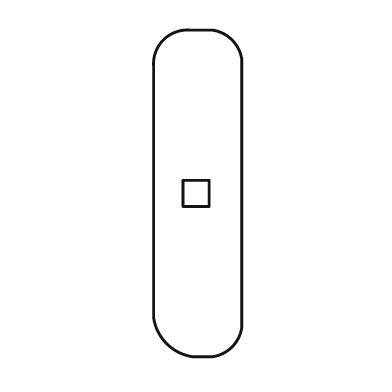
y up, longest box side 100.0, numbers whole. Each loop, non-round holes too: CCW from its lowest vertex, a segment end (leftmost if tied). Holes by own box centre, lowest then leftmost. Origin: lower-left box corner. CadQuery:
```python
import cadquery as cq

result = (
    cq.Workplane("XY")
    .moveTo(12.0, 0.0)
    .lineTo(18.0, 0.0)
    .threePointArc((24.0, 3.0), (27.0, 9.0))
    .lineTo(27.0, 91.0)
    .threePointArc((24.0, 97.0), (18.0, 100.0))
    .lineTo(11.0, 100.0)
    .threePointArc((3.0, 97.0), (0.0, 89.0))
    .lineTo(0.0, 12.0)
    .threePointArc((4.0, 4.0), (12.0, 0.0))
    .close()
    .moveTo(9.0, 46.0)
    .lineTo(17.0, 46.0)
    .lineTo(17.0, 54.0)
    .lineTo(9.0, 54.0)
    .close()
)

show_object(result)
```